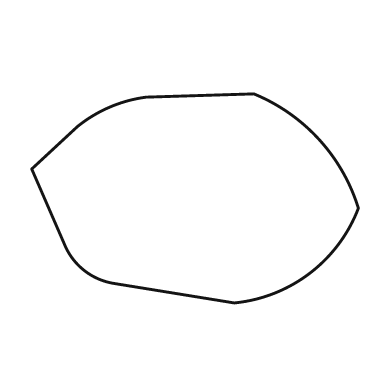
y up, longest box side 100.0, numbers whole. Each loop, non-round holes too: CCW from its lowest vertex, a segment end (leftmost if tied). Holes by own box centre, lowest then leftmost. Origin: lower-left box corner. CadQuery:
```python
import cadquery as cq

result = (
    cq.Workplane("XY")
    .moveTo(62.0, 0.0)
    .threePointArc((85.0, 9.0), (100.0, 29.0))
    .threePointArc((88.0, 50.0), (68.0, 64.0))
    .lineTo(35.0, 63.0)
    .threePointArc((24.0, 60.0), (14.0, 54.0))
    .lineTo(0.0, 41.0)
    .lineTo(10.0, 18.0)
    .threePointArc((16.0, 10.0), (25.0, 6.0))
    .close()
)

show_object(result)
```